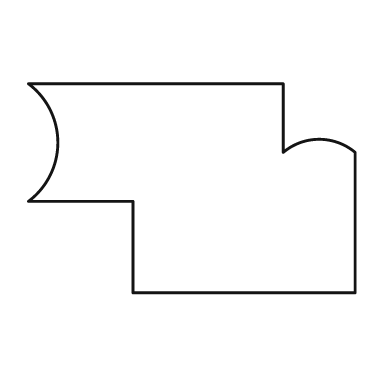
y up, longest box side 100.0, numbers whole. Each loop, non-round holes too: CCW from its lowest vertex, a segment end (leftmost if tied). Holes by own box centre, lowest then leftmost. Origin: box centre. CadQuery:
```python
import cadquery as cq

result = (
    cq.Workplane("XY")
    .moveTo(-18.0, -32.0)
    .lineTo(50.0, -32.0)
    .lineTo(50.0, 11.0)
    .threePointArc((39.0, 15.0), (28.0, 11.0))
    .lineTo(28.0, 32.0)
    .lineTo(-50.0, 32.0)
    .threePointArc((-41.0, 14.0), (-50.0, -4.0))
    .lineTo(-18.0, -4.0)
    .close()
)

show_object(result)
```